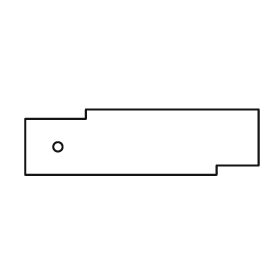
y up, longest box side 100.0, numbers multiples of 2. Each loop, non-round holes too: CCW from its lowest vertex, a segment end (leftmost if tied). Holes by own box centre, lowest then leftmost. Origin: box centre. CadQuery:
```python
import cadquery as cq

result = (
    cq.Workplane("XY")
    .moveTo(-50.0, -14.0)
    .lineTo(32.0, -14.0)
    .lineTo(32.0, -10.0)
    .lineTo(50.0, -10.0)
    .lineTo(50.0, 14.0)
    .lineTo(-24.0, 14.0)
    .lineTo(-24.0, 10.0)
    .lineTo(-50.0, 10.0)
    .close()
    .moveTo(-36.0, -2.0)
    .circle(2.0)
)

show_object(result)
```